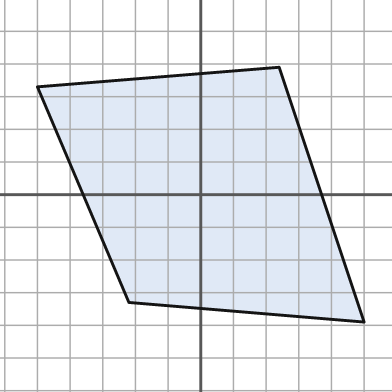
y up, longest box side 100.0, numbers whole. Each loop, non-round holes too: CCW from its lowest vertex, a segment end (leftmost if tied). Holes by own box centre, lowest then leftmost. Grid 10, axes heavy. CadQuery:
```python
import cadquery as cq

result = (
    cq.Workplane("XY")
    .moveTo(50.0, -39.0)
    .lineTo(24.0, 39.0)
    .lineTo(-50.0, 33.0)
    .lineTo(-22.0, -33.0)
    .close()
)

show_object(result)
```